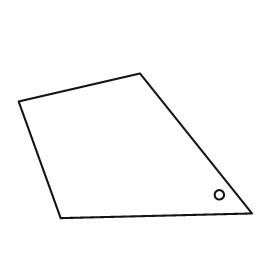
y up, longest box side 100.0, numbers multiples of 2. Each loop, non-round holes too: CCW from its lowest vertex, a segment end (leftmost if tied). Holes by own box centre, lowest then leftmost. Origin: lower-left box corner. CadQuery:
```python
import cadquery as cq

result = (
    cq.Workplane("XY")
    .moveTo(18.0, 0.0)
    .lineTo(100.0, 2.0)
    .lineTo(52.0, 62.0)
    .lineTo(0.0, 50.0)
    .close()
    .moveTo(86.0, 10.0)
    .circle(2.0)
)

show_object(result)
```